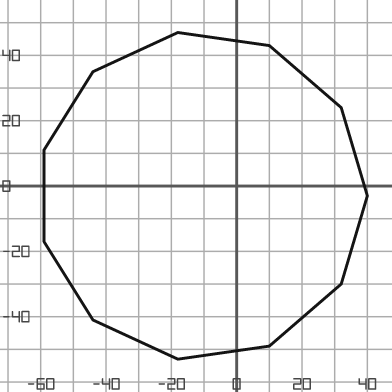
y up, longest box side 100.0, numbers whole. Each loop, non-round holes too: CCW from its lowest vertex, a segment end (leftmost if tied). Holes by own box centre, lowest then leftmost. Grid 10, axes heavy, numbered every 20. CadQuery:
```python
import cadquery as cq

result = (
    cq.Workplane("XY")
    .moveTo(-18.0, -53.0)
    .lineTo(10.0, -49.0)
    .lineTo(32.0, -30.0)
    .lineTo(40.0, -3.0)
    .lineTo(32.0, 24.0)
    .lineTo(10.0, 43.0)
    .lineTo(-18.0, 47.0)
    .lineTo(-44.0, 35.0)
    .lineTo(-59.0, 11.0)
    .lineTo(-59.0, -17.0)
    .lineTo(-44.0, -41.0)
    .close()
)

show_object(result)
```